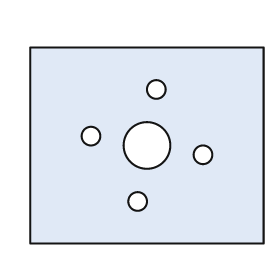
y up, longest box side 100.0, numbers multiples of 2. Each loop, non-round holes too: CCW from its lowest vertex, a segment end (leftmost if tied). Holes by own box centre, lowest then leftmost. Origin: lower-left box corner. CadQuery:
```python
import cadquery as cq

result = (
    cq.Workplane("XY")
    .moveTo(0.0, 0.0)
    .lineTo(100.0, 0.0)
    .lineTo(100.0, 84.0)
    .lineTo(0.0, 84.0)
    .close()
    .moveTo(46.0, 18.0)
    .circle(4.0)
    .moveTo(74.0, 38.0)
    .circle(4.0)
    .moveTo(50.0, 42.0)
    .circle(10.0)
    .moveTo(26.0, 46.0)
    .circle(4.0)
    .moveTo(54.0, 66.0)
    .circle(4.0)
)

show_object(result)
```